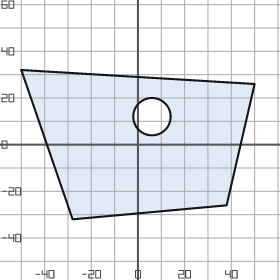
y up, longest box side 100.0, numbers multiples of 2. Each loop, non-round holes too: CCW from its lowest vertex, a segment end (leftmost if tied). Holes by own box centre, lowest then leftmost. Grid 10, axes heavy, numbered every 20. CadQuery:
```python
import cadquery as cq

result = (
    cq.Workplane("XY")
    .moveTo(-28.0, -32.0)
    .lineTo(38.0, -26.0)
    .lineTo(50.0, 26.0)
    .lineTo(-50.0, 32.0)
    .close()
    .moveTo(6.0, 12.0)
    .circle(8.0)
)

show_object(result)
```